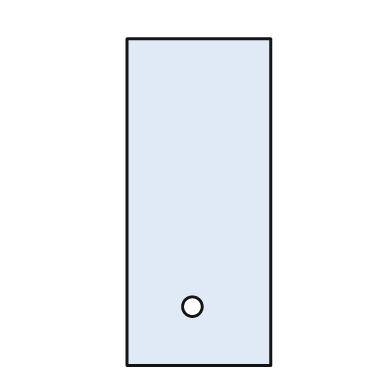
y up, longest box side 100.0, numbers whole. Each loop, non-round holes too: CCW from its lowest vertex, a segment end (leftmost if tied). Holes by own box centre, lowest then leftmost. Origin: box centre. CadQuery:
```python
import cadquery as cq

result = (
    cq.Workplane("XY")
    .moveTo(-22.0, -50.0)
    .lineTo(22.0, -50.0)
    .lineTo(22.0, 50.0)
    .lineTo(-22.0, 50.0)
    .close()
    .moveTo(-2.0, -32.0)
    .circle(3.0)
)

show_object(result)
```